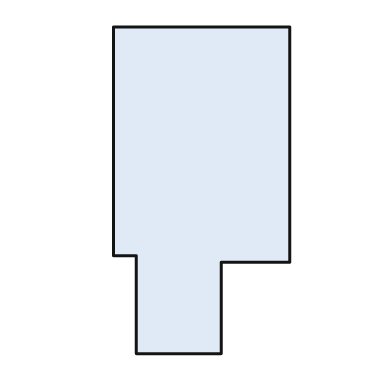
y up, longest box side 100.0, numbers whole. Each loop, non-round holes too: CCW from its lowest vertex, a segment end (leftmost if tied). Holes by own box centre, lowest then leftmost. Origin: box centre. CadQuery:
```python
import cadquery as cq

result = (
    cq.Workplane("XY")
    .moveTo(-20.0, -50.0)
    .lineTo(6.0, -50.0)
    .lineTo(6.0, -22.0)
    .lineTo(27.0, -22.0)
    .lineTo(27.0, 50.0)
    .lineTo(-27.0, 50.0)
    .lineTo(-27.0, -20.0)
    .lineTo(-20.0, -20.0)
    .close()
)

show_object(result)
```